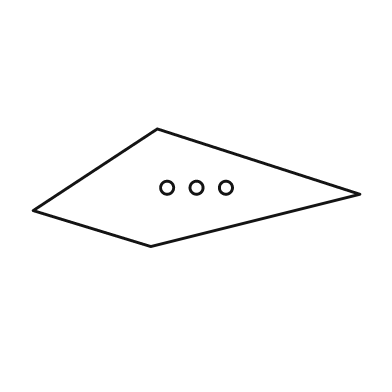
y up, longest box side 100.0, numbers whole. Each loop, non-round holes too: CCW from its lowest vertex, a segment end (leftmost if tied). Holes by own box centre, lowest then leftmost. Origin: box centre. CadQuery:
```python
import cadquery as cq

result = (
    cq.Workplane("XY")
    .moveTo(-14.0, -18.0)
    .lineTo(50.0, -2.0)
    .lineTo(-12.0, 18.0)
    .lineTo(-50.0, -7.0)
    .close()
    .moveTo(-9.0, 0.0)
    .circle(2.0)
    .moveTo(0.0, 0.0)
    .circle(2.0)
    .moveTo(9.0, 0.0)
    .circle(2.0)
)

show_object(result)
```